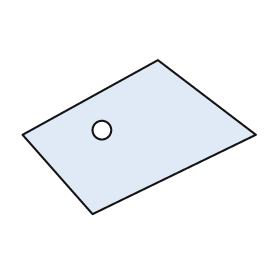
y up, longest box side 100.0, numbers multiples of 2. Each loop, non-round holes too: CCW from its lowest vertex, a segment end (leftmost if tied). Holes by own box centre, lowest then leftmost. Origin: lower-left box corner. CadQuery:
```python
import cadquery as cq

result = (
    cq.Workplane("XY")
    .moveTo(30.0, 0.0)
    .lineTo(100.0, 34.0)
    .lineTo(58.0, 66.0)
    .lineTo(0.0, 34.0)
    .close()
    .moveTo(34.0, 36.0)
    .circle(4.0)
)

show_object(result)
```